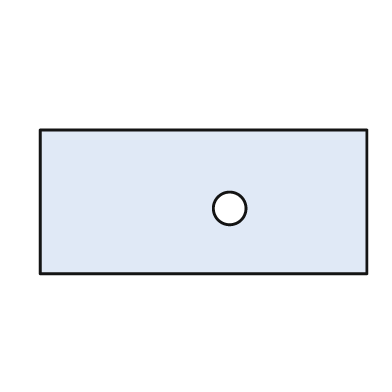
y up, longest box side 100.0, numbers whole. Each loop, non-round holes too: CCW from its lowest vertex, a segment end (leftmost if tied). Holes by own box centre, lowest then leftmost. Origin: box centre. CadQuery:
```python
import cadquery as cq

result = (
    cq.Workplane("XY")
    .moveTo(-50.0, -22.0)
    .lineTo(50.0, -22.0)
    .lineTo(50.0, 22.0)
    .lineTo(-50.0, 22.0)
    .close()
    .moveTo(8.0, -2.0)
    .circle(5.0)
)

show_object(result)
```